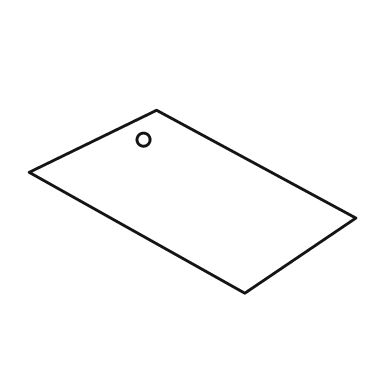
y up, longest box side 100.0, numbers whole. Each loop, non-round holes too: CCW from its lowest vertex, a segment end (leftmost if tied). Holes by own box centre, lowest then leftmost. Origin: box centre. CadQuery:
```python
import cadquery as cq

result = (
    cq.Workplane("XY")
    .moveTo(16.0, -28.0)
    .lineTo(50.0, -5.0)
    .lineTo(-11.0, 28.0)
    .lineTo(-50.0, 9.0)
    .close()
    .moveTo(-15.0, 19.0)
    .circle(2.0)
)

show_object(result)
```